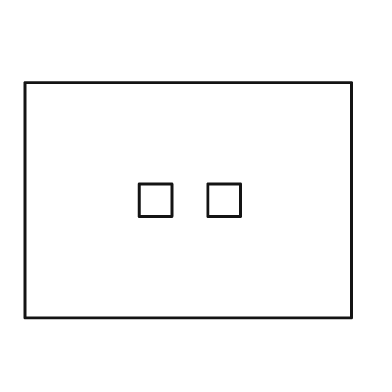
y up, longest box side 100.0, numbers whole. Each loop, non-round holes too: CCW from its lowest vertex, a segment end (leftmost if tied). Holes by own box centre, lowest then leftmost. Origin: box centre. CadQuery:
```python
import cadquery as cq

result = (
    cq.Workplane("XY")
    .moveTo(-50.0, -36.0)
    .lineTo(50.0, -36.0)
    .lineTo(50.0, 36.0)
    .lineTo(-50.0, 36.0)
    .close()
    .moveTo(-15.0, -5.0)
    .lineTo(-5.0, -5.0)
    .lineTo(-5.0, 5.0)
    .lineTo(-15.0, 5.0)
    .close()
    .moveTo(6.0, -5.0)
    .lineTo(16.0, -5.0)
    .lineTo(16.0, 5.0)
    .lineTo(6.0, 5.0)
    .close()
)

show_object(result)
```